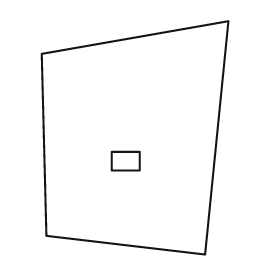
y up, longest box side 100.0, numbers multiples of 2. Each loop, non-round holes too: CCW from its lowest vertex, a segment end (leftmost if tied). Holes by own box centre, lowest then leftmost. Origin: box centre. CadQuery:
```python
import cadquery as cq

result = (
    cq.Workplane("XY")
    .moveTo(30.0, -50.0)
    .lineTo(40.0, 50.0)
    .lineTo(-40.0, 36.0)
    .lineTo(-38.0, -42.0)
    .close()
    .moveTo(-10.0, -14.0)
    .lineTo(2.0, -14.0)
    .lineTo(2.0, -6.0)
    .lineTo(-10.0, -6.0)
    .close()
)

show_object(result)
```